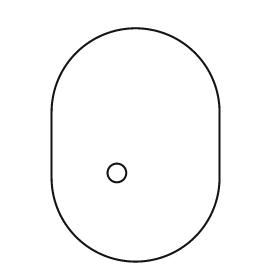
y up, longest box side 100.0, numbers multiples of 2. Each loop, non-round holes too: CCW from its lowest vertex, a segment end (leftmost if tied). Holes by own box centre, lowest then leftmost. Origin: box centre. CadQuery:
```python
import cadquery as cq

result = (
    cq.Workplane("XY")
    .moveTo(-36.0, -14.0)
    .threePointArc((0.0, -50.0), (36.0, -14.0))
    .lineTo(36.0, 14.0)
    .threePointArc((0.0, 50.0), (-36.0, 14.0))
    .close()
    .moveTo(-8.0, -12.0)
    .circle(4.0)
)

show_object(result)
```